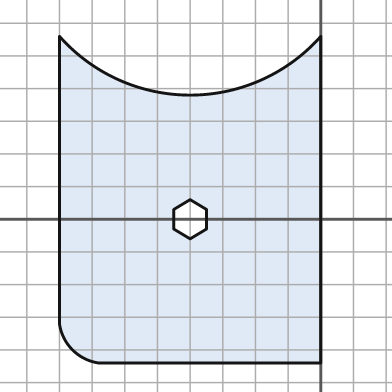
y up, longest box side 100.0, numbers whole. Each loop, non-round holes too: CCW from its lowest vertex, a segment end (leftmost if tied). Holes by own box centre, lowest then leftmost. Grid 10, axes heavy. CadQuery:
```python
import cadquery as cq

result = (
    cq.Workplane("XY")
    .moveTo(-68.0, -44.0)
    .lineTo(0.0, -44.0)
    .lineTo(0.0, 56.0)
    .threePointArc((-40.0, 38.0), (-80.0, 56.0))
    .lineTo(-80.0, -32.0)
    .threePointArc((-76.0, -40.0), (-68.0, -44.0))
    .close()
    .moveTo(-40.0, -6.0)
    .lineTo(-35.0, -3.0)
    .lineTo(-35.0, 3.0)
    .lineTo(-40.0, 6.0)
    .lineTo(-45.0, 3.0)
    .lineTo(-45.0, -3.0)
    .close()
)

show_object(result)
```